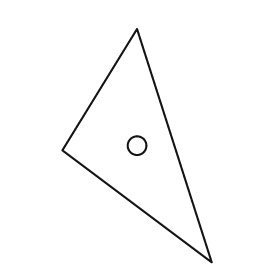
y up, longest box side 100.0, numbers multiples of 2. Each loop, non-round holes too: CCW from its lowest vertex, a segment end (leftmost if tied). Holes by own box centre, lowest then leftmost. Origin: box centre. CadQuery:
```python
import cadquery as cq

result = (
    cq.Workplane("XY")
    .moveTo(32.0, -50.0)
    .lineTo(0.0, 50.0)
    .lineTo(-32.0, -2.0)
    .close()
    .moveTo(0.0, 0.0)
    .circle(4.0)
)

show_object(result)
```